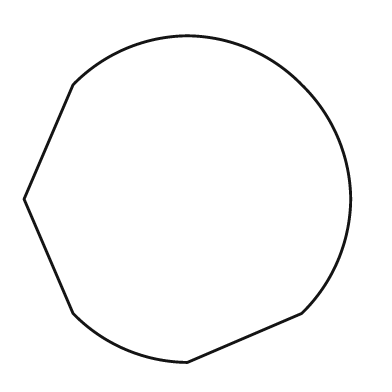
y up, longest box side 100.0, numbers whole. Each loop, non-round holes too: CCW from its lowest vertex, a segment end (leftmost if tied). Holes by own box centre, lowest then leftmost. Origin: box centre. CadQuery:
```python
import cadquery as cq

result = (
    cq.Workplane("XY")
    .moveTo(0.0, -50.0)
    .lineTo(35.0, -35.0)
    .threePointArc((46.0, -19.0), (50.0, 0.0))
    .threePointArc((46.0, 19.0), (35.0, 35.0))
    .threePointArc((19.0, 46.0), (0.0, 50.0))
    .threePointArc((-19.0, 46.0), (-35.0, 35.0))
    .lineTo(-50.0, 0.0)
    .lineTo(-35.0, -35.0)
    .threePointArc((-19.0, -46.0), (0.0, -50.0))
    .close()
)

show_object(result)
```